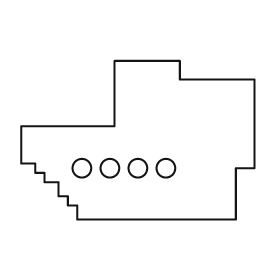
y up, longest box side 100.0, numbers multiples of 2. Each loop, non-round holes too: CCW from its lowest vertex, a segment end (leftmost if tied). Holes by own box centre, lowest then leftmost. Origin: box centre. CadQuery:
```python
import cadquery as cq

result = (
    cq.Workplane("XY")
    .moveTo(-26.0, -34.0)
    .lineTo(42.0, -34.0)
    .lineTo(42.0, -12.0)
    .lineTo(50.0, -12.0)
    .lineTo(50.0, 26.0)
    .lineTo(18.0, 26.0)
    .lineTo(18.0, 34.0)
    .lineTo(-10.0, 34.0)
    .lineTo(-10.0, 6.0)
    .lineTo(-50.0, 6.0)
    .lineTo(-50.0, -10.0)
    .lineTo(-44.0, -10.0)
    .lineTo(-44.0, -14.0)
    .lineTo(-40.0, -14.0)
    .lineTo(-40.0, -18.0)
    .lineTo(-34.0, -18.0)
    .lineTo(-34.0, -24.0)
    .lineTo(-30.0, -24.0)
    .lineTo(-30.0, -28.0)
    .lineTo(-26.0, -28.0)
    .close()
    .moveTo(-24.0, -12.0)
    .circle(4.0)
    .moveTo(-12.0, -12.0)
    .circle(4.0)
    .moveTo(0.0, -12.0)
    .circle(4.0)
    .moveTo(12.0, -12.0)
    .circle(4.0)
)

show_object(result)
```